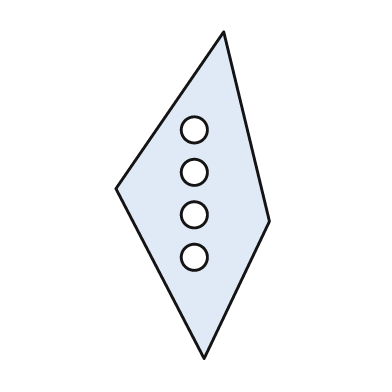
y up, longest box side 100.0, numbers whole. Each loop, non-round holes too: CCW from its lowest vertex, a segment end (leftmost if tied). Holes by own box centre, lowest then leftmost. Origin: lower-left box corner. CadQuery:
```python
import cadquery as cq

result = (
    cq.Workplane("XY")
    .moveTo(27.0, 0.0)
    .lineTo(47.0, 42.0)
    .lineTo(33.0, 100.0)
    .lineTo(0.0, 52.0)
    .close()
    .moveTo(24.0, 31.0)
    .circle(4.0)
    .moveTo(24.0, 44.0)
    .circle(4.0)
    .moveTo(24.0, 57.0)
    .circle(4.0)
    .moveTo(24.0, 70.0)
    .circle(4.0)
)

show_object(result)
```